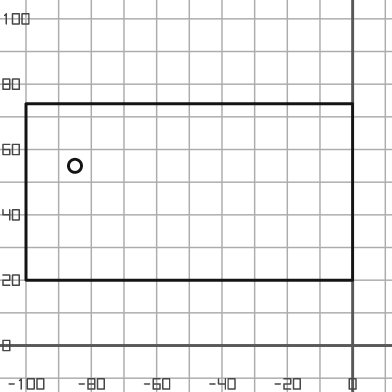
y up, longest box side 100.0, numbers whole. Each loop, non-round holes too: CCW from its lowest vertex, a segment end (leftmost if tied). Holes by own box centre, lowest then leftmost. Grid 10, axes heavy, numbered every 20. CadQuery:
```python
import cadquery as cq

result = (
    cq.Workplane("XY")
    .moveTo(-100.0, 20.0)
    .lineTo(0.0, 20.0)
    .lineTo(0.0, 74.0)
    .lineTo(-100.0, 74.0)
    .close()
    .moveTo(-85.0, 55.0)
    .circle(2.0)
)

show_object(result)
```